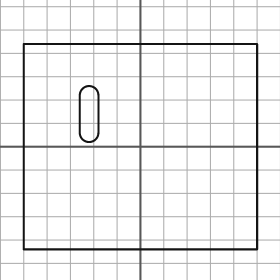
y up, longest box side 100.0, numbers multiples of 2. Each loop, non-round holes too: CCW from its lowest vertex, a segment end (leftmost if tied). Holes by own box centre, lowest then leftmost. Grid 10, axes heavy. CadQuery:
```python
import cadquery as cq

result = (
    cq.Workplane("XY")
    .moveTo(-50.0, -44.0)
    .lineTo(50.0, -44.0)
    .lineTo(50.0, 44.0)
    .lineTo(-50.0, 44.0)
    .close()
    .moveTo(-26.0, 6.0)
    .threePointArc((-22.0, 2.0), (-18.0, 6.0))
    .lineTo(-18.0, 22.0)
    .threePointArc((-22.0, 26.0), (-26.0, 22.0))
    .close()
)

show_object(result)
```